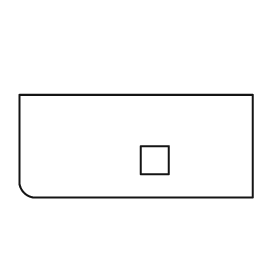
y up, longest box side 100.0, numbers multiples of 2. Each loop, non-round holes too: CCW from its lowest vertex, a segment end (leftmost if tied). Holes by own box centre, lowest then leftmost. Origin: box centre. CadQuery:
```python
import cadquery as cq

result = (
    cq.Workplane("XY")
    .moveTo(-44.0, -22.0)
    .lineTo(50.0, -22.0)
    .lineTo(50.0, 22.0)
    .lineTo(-50.0, 22.0)
    .lineTo(-50.0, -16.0)
    .threePointArc((-48.0, -20.0), (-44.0, -22.0))
    .close()
    .moveTo(2.0, -12.0)
    .lineTo(14.0, -12.0)
    .lineTo(14.0, 0.0)
    .lineTo(2.0, 0.0)
    .close()
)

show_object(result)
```